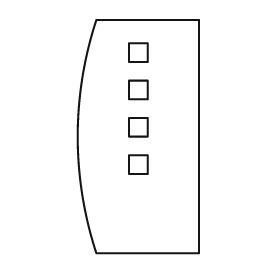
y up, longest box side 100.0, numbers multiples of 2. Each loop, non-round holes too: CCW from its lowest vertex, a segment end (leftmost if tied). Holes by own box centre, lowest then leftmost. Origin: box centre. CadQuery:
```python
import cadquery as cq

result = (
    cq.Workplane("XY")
    .moveTo(-18.0, -50.0)
    .lineTo(26.0, -50.0)
    .lineTo(26.0, 50.0)
    .lineTo(-18.0, 50.0)
    .threePointArc((-26.0, 0.0), (-18.0, -50.0))
    .close()
    .moveTo(-4.0, -16.0)
    .lineTo(4.0, -16.0)
    .lineTo(4.0, -8.0)
    .lineTo(-4.0, -8.0)
    .close()
    .moveTo(-4.0, 0.0)
    .lineTo(4.0, 0.0)
    .lineTo(4.0, 8.0)
    .lineTo(-4.0, 8.0)
    .close()
    .moveTo(-4.0, 16.0)
    .lineTo(4.0, 16.0)
    .lineTo(4.0, 24.0)
    .lineTo(-4.0, 24.0)
    .close()
    .moveTo(-4.0, 32.0)
    .lineTo(4.0, 32.0)
    .lineTo(4.0, 40.0)
    .lineTo(-4.0, 40.0)
    .close()
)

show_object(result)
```